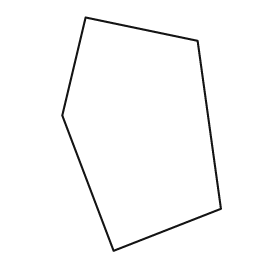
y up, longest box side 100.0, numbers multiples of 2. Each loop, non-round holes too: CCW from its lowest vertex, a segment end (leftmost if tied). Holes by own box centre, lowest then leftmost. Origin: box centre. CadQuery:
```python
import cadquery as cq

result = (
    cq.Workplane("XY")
    .moveTo(-12.0, -50.0)
    .lineTo(34.0, -32.0)
    .lineTo(24.0, 40.0)
    .lineTo(-24.0, 50.0)
    .lineTo(-34.0, 8.0)
    .close()
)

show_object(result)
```